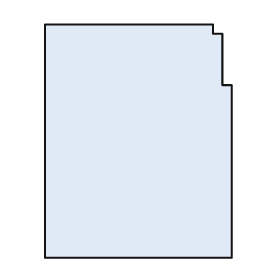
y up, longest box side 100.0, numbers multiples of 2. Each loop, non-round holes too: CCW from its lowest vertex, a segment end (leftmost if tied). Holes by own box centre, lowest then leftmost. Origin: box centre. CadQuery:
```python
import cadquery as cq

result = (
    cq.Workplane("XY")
    .moveTo(-40.0, -50.0)
    .lineTo(40.0, -50.0)
    .lineTo(40.0, 24.0)
    .lineTo(36.0, 24.0)
    .lineTo(36.0, 46.0)
    .lineTo(32.0, 46.0)
    .lineTo(32.0, 50.0)
    .lineTo(-40.0, 50.0)
    .close()
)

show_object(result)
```